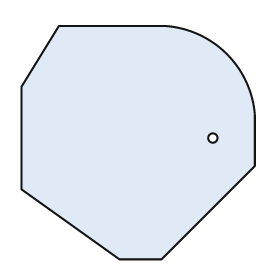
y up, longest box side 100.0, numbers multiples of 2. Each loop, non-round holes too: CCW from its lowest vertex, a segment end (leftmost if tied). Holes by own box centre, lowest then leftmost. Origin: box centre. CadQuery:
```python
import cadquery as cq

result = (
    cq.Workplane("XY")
    .moveTo(-8.0, -50.0)
    .lineTo(10.0, -50.0)
    .lineTo(50.0, -10.0)
    .lineTo(50.0, 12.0)
    .threePointArc((38.0, 38.0), (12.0, 50.0))
    .lineTo(-34.0, 50.0)
    .lineTo(-50.0, 24.0)
    .lineTo(-50.0, -20.0)
    .close()
    .moveTo(32.0, 2.0)
    .circle(2.0)
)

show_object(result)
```